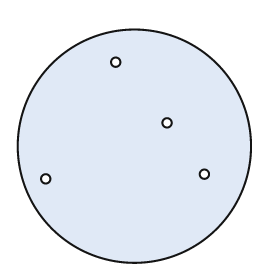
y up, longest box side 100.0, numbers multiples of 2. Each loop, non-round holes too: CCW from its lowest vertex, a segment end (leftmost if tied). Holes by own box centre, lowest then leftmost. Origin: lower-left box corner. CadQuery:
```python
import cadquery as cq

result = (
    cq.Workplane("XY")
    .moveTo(50.0, 50.0)
    .circle(50.0)
    .moveTo(12.0, 36.0)
    .circle(2.0)
    .moveTo(80.0, 38.0)
    .circle(2.0)
    .moveTo(64.0, 60.0)
    .circle(2.0)
    .moveTo(42.0, 86.0)
    .circle(2.0)
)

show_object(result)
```